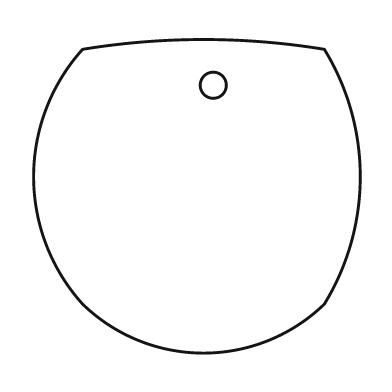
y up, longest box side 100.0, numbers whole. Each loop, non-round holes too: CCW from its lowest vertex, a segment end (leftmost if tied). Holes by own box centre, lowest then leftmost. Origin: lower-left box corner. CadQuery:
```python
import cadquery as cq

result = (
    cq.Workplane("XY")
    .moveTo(15.0, 15.0)
    .threePointArc((52.0, 0.0), (89.0, 15.0))
    .threePointArc((100.0, 54.0), (89.0, 93.0))
    .threePointArc((52.0, 96.0), (15.0, 93.0))
    .threePointArc((0.0, 54.0), (15.0, 15.0))
    .close()
    .moveTo(55.0, 82.0)
    .circle(4.0)
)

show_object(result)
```